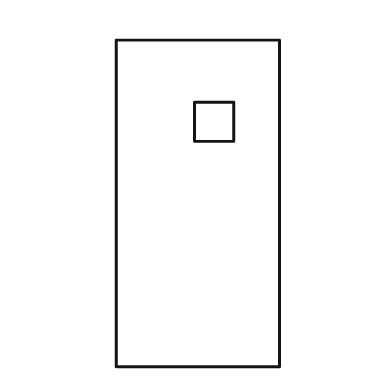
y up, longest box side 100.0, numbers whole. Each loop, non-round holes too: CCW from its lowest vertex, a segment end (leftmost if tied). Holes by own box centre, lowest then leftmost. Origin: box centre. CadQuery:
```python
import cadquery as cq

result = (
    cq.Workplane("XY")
    .moveTo(-25.0, -50.0)
    .lineTo(25.0, -50.0)
    .lineTo(25.0, 50.0)
    .lineTo(-25.0, 50.0)
    .close()
    .moveTo(-1.0, 19.0)
    .lineTo(11.0, 19.0)
    .lineTo(11.0, 31.0)
    .lineTo(-1.0, 31.0)
    .close()
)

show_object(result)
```